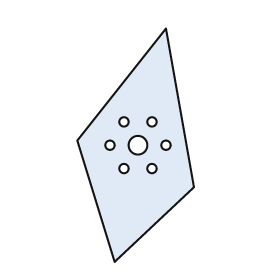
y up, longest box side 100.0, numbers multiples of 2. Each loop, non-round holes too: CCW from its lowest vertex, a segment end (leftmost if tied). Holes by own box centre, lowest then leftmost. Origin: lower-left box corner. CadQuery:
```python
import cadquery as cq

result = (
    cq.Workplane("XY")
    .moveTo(16.0, 0.0)
    .lineTo(50.0, 32.0)
    .lineTo(38.0, 100.0)
    .lineTo(0.0, 52.0)
    .close()
    .moveTo(20.0, 40.0)
    .circle(2.0)
    .moveTo(32.0, 40.0)
    .circle(2.0)
    .moveTo(14.0, 50.0)
    .circle(2.0)
    .moveTo(26.0, 50.0)
    .circle(4.0)
    .moveTo(38.0, 50.0)
    .circle(2.0)
    .moveTo(20.0, 60.0)
    .circle(2.0)
    .moveTo(32.0, 60.0)
    .circle(2.0)
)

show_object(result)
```